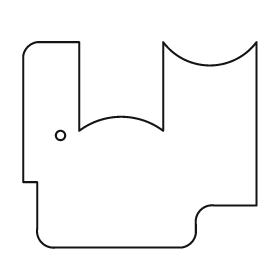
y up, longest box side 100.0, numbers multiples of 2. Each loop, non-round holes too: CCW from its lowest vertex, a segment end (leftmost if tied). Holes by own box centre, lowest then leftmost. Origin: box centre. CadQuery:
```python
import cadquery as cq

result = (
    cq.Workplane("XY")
    .moveTo(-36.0, -44.0)
    .lineTo(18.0, -44.0)
    .threePointArc((22.0, -42.0), (24.0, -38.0))
    .lineTo(24.0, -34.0)
    .threePointArc((26.0, -28.0), (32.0, -26.0))
    .lineTo(50.0, -26.0)
    .lineTo(50.0, 44.0)
    .threePointArc((30.0, 34.0), (10.0, 44.0))
    .lineTo(10.0, 6.0)
    .threePointArc((-8.0, 12.0), (-26.0, 6.0))
    .lineTo(-26.0, 44.0)
    .lineTo(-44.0, 44.0)
    .threePointArc((-48.0, 42.0), (-50.0, 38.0))
    .lineTo(-50.0, -16.0)
    .lineTo(-44.0, -16.0)
    .lineTo(-44.0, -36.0)
    .threePointArc((-42.0, -42.0), (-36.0, -44.0))
    .close()
    .moveTo(-34.0, 4.0)
    .circle(2.0)
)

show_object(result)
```